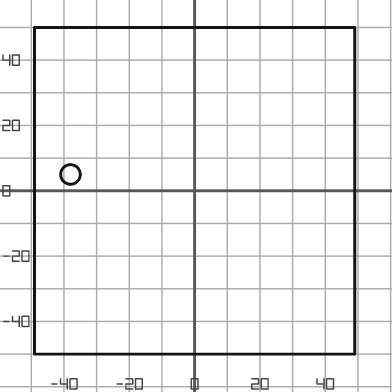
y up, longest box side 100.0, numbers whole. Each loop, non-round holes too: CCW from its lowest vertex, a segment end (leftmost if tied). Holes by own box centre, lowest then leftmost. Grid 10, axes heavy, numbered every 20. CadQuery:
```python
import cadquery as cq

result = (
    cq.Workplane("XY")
    .moveTo(-49.0, -50.0)
    .lineTo(49.0, -50.0)
    .lineTo(49.0, 50.0)
    .lineTo(-49.0, 50.0)
    .close()
    .moveTo(-38.0, 5.0)
    .circle(3.0)
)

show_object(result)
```